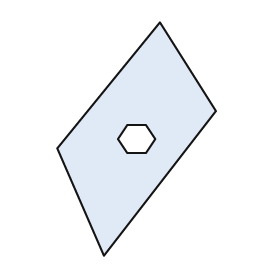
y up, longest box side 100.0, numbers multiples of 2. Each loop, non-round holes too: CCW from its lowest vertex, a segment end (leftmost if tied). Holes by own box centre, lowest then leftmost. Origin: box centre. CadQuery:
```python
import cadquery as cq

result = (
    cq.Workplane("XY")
    .moveTo(-14.0, -50.0)
    .lineTo(34.0, 12.0)
    .lineTo(10.0, 50.0)
    .lineTo(-34.0, -4.0)
    .close()
    .moveTo(-4.0, -6.0)
    .lineTo(4.0, -6.0)
    .lineTo(8.0, 0.0)
    .lineTo(4.0, 6.0)
    .lineTo(-4.0, 6.0)
    .lineTo(-8.0, 0.0)
    .close()
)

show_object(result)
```